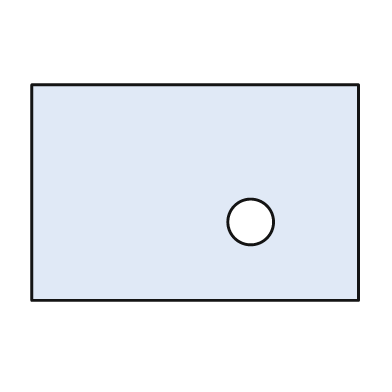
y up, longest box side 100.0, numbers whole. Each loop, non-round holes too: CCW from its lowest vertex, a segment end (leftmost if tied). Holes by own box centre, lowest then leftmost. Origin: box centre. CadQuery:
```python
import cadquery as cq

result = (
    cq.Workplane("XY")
    .moveTo(-50.0, -33.0)
    .lineTo(50.0, -33.0)
    .lineTo(50.0, 33.0)
    .lineTo(-50.0, 33.0)
    .close()
    .moveTo(17.0, -9.0)
    .circle(7.0)
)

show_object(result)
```